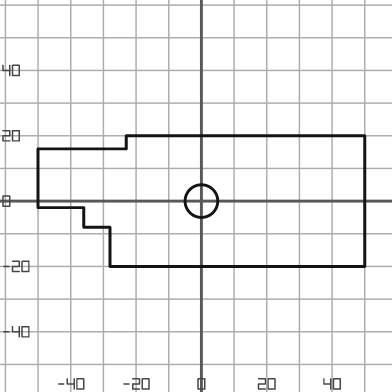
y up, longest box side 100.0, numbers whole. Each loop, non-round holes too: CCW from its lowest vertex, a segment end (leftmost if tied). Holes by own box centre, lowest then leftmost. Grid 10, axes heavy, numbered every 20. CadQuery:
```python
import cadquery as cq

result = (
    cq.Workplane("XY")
    .moveTo(-28.0, -20.0)
    .lineTo(50.0, -20.0)
    .lineTo(50.0, 20.0)
    .lineTo(-23.0, 20.0)
    .lineTo(-23.0, 16.0)
    .lineTo(-50.0, 16.0)
    .lineTo(-50.0, -2.0)
    .lineTo(-36.0, -2.0)
    .lineTo(-36.0, -8.0)
    .lineTo(-28.0, -8.0)
    .close()
    .moveTo(0.0, 0.0)
    .circle(5.0)
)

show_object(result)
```